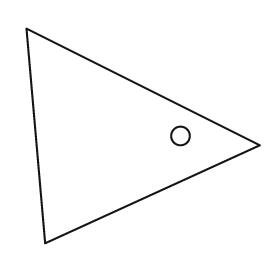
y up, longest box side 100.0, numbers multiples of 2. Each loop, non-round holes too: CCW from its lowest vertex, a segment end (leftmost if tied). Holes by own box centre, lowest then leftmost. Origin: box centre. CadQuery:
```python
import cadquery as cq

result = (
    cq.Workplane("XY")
    .moveTo(-42.0, -46.0)
    .lineTo(50.0, -4.0)
    .lineTo(-50.0, 46.0)
    .close()
    .moveTo(16.0, 0.0)
    .circle(4.0)
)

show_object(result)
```